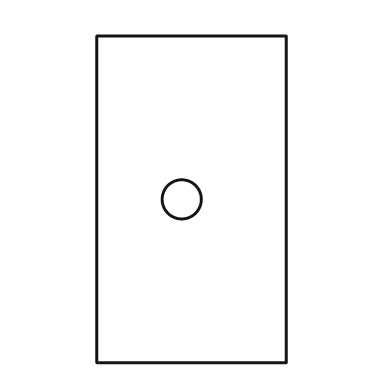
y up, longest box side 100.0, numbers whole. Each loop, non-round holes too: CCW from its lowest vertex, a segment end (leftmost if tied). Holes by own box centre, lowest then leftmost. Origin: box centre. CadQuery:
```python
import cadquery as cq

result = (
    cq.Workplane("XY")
    .moveTo(-29.0, -50.0)
    .lineTo(29.0, -50.0)
    .lineTo(29.0, 50.0)
    .lineTo(-29.0, 50.0)
    .close()
    .moveTo(-3.0, 0.0)
    .circle(6.0)
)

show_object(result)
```